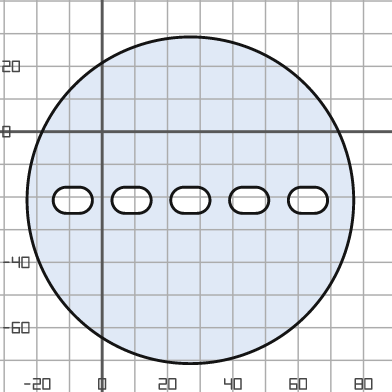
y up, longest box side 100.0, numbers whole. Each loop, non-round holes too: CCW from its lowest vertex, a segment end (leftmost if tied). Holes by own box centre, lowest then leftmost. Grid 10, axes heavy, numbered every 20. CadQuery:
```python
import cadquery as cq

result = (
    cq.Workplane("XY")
    .moveTo(27.0, -21.0)
    .circle(50.0)
    .moveTo(-11.0, -25.0)
    .lineTo(-7.0, -25.0)
    .threePointArc((-3.0, -21.0), (-7.0, -17.0))
    .lineTo(-11.0, -17.0)
    .threePointArc((-15.0, -21.0), (-11.0, -25.0))
    .close()
    .moveTo(7.0, -25.0)
    .lineTo(11.0, -25.0)
    .threePointArc((15.0, -21.0), (11.0, -17.0))
    .lineTo(7.0, -17.0)
    .threePointArc((3.0, -21.0), (7.0, -25.0))
    .close()
    .moveTo(25.0, -25.0)
    .lineTo(29.0, -25.0)
    .threePointArc((33.0, -21.0), (29.0, -17.0))
    .lineTo(25.0, -17.0)
    .threePointArc((21.0, -21.0), (25.0, -25.0))
    .close()
    .moveTo(43.0, -25.0)
    .lineTo(47.0, -25.0)
    .threePointArc((51.0, -21.0), (47.0, -17.0))
    .lineTo(43.0, -17.0)
    .threePointArc((39.0, -21.0), (43.0, -25.0))
    .close()
    .moveTo(61.0, -25.0)
    .lineTo(65.0, -25.0)
    .threePointArc((69.0, -21.0), (65.0, -17.0))
    .lineTo(61.0, -17.0)
    .threePointArc((57.0, -21.0), (61.0, -25.0))
    .close()
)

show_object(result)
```